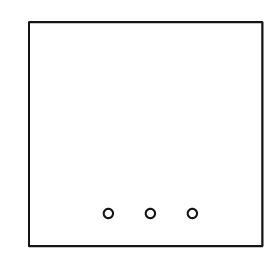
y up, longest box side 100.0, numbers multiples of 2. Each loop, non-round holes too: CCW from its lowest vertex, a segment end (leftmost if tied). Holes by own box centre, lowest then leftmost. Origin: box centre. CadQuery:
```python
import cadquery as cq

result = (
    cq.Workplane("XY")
    .moveTo(-50.0, -48.0)
    .lineTo(50.0, -48.0)
    .lineTo(50.0, 48.0)
    .lineTo(-50.0, 48.0)
    .close()
    .moveTo(-16.0, -34.0)
    .circle(2.0)
    .moveTo(2.0, -34.0)
    .circle(2.0)
    .moveTo(20.0, -34.0)
    .circle(2.0)
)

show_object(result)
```